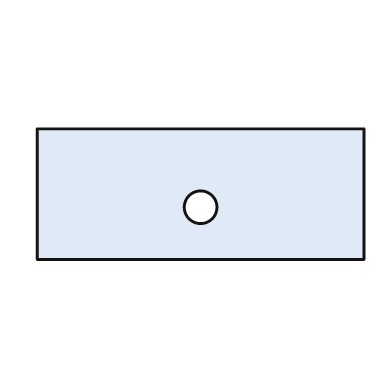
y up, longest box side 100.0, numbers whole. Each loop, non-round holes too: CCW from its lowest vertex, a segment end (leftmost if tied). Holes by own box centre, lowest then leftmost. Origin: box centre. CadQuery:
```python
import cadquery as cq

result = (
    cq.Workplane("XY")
    .moveTo(-50.0, -20.0)
    .lineTo(50.0, -20.0)
    .lineTo(50.0, 20.0)
    .lineTo(-50.0, 20.0)
    .close()
    .moveTo(0.0, -4.0)
    .circle(5.0)
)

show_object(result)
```